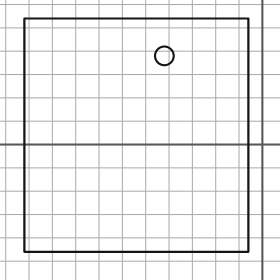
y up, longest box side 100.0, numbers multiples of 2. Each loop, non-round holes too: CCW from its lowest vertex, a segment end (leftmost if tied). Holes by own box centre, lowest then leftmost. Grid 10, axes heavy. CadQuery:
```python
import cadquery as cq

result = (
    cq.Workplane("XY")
    .moveTo(-102.0, -46.0)
    .lineTo(-6.0, -46.0)
    .lineTo(-6.0, 54.0)
    .lineTo(-102.0, 54.0)
    .close()
    .moveTo(-42.0, 38.0)
    .circle(4.0)
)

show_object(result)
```